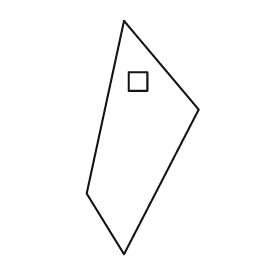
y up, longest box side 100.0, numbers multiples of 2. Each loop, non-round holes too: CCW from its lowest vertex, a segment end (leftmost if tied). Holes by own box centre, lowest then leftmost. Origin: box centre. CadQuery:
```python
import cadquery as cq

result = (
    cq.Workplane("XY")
    .moveTo(-8.0, -50.0)
    .lineTo(24.0, 12.0)
    .lineTo(-8.0, 50.0)
    .lineTo(-24.0, -24.0)
    .close()
    .moveTo(-6.0, 20.0)
    .lineTo(2.0, 20.0)
    .lineTo(2.0, 28.0)
    .lineTo(-6.0, 28.0)
    .close()
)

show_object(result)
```